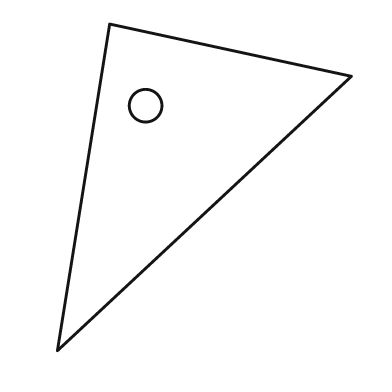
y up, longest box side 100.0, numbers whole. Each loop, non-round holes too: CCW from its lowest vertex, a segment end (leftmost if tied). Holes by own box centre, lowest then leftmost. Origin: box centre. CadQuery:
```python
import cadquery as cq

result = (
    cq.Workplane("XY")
    .moveTo(-45.0, -50.0)
    .lineTo(45.0, 34.0)
    .lineTo(-29.0, 50.0)
    .close()
    .moveTo(-18.0, 25.0)
    .circle(5.0)
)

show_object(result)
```